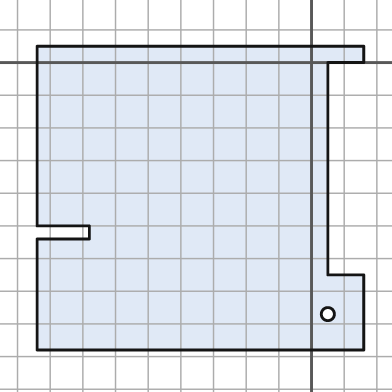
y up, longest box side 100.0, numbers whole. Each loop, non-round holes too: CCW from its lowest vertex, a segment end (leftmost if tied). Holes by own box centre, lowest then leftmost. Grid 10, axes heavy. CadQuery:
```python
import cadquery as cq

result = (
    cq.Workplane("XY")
    .moveTo(-84.0, -88.0)
    .lineTo(16.0, -88.0)
    .lineTo(16.0, -65.0)
    .lineTo(5.0, -65.0)
    .lineTo(5.0, 0.0)
    .lineTo(16.0, 0.0)
    .lineTo(16.0, 5.0)
    .lineTo(-84.0, 5.0)
    .lineTo(-84.0, -50.0)
    .lineTo(-68.0, -50.0)
    .lineTo(-68.0, -54.0)
    .lineTo(-84.0, -54.0)
    .close()
    .moveTo(5.0, -77.0)
    .circle(2.0)
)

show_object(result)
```